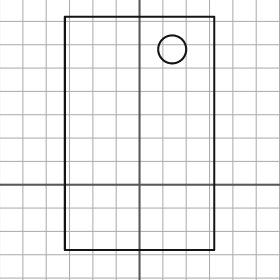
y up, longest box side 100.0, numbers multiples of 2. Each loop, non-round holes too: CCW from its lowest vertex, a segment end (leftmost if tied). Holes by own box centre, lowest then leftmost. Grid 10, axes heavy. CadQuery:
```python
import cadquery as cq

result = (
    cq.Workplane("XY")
    .moveTo(-32.0, -28.0)
    .lineTo(32.0, -28.0)
    .lineTo(32.0, 72.0)
    .lineTo(-32.0, 72.0)
    .close()
    .moveTo(14.0, 58.0)
    .circle(6.0)
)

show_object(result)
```